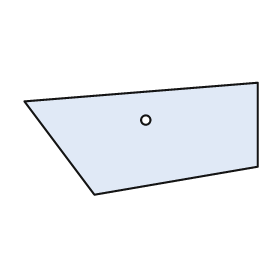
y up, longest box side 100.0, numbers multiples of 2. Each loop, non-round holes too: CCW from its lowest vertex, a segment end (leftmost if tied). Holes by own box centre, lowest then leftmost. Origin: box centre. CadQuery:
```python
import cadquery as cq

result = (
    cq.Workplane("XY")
    .moveTo(-20.0, -24.0)
    .lineTo(50.0, -12.0)
    .lineTo(50.0, 24.0)
    .lineTo(-50.0, 16.0)
    .close()
    .moveTo(2.0, 8.0)
    .circle(2.0)
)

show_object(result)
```